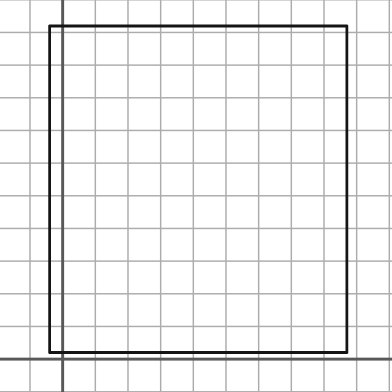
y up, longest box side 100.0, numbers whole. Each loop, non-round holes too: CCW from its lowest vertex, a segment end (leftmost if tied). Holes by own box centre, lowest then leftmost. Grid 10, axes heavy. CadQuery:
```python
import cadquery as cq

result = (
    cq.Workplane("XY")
    .moveTo(-4.0, 2.0)
    .lineTo(87.0, 2.0)
    .lineTo(87.0, 102.0)
    .lineTo(-4.0, 102.0)
    .close()
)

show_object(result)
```